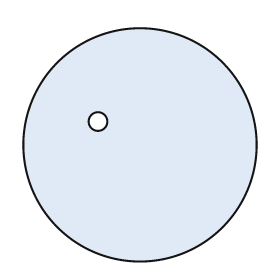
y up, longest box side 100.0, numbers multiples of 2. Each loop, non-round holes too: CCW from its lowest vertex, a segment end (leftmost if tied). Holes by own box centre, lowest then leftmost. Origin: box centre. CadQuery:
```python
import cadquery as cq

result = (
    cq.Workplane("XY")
    .moveTo(0.0, 0.0)
    .circle(50.0)
    .moveTo(-18.0, 10.0)
    .circle(4.0)
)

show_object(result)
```